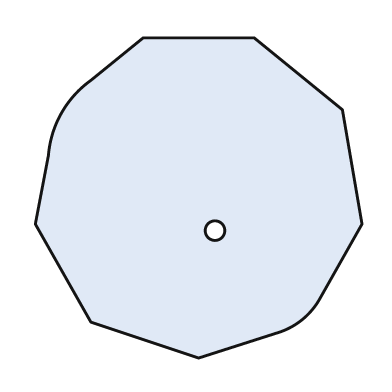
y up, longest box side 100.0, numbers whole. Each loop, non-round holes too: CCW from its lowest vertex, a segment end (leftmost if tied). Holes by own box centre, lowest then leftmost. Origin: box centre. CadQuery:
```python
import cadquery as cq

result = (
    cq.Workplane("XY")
    .moveTo(0.0, -49.0)
    .lineTo(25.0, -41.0)
    .threePointArc((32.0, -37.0), (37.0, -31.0))
    .lineTo(50.0, -8.0)
    .lineTo(44.0, 27.0)
    .lineTo(17.0, 49.0)
    .lineTo(-17.0, 49.0)
    .lineTo(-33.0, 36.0)
    .threePointArc((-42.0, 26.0), (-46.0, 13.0))
    .lineTo(-50.0, -8.0)
    .lineTo(-33.0, -38.0)
    .close()
    .moveTo(5.0, -10.0)
    .circle(3.0)
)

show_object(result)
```